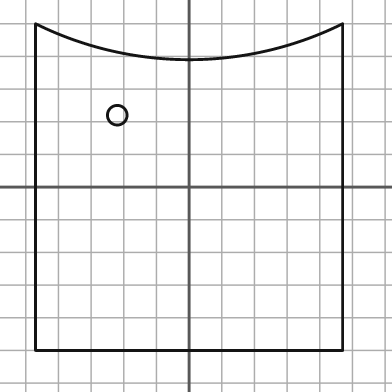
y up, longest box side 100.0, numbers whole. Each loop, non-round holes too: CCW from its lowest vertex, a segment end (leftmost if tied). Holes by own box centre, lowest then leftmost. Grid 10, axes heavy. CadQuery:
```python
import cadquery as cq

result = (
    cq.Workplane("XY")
    .moveTo(-47.0, -50.0)
    .lineTo(47.0, -50.0)
    .lineTo(47.0, 50.0)
    .threePointArc((0.0, 39.0), (-47.0, 50.0))
    .close()
    .moveTo(-22.0, 22.0)
    .circle(3.0)
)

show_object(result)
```